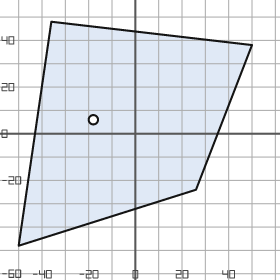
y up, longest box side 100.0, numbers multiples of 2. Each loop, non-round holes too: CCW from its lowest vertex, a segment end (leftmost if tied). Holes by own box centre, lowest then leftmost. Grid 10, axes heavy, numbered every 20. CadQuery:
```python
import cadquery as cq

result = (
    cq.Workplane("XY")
    .moveTo(-50.0, -48.0)
    .lineTo(26.0, -24.0)
    .lineTo(50.0, 38.0)
    .lineTo(-36.0, 48.0)
    .close()
    .moveTo(-18.0, 6.0)
    .circle(2.0)
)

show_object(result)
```